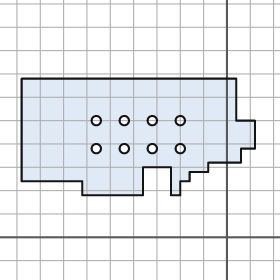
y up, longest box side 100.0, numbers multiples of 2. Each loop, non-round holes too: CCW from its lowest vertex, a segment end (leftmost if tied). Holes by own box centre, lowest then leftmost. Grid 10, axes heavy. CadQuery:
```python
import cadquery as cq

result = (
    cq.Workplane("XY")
    .moveTo(-62.0, 18.0)
    .lineTo(-36.0, 18.0)
    .lineTo(-36.0, 30.0)
    .lineTo(-24.0, 30.0)
    .lineTo(-24.0, 18.0)
    .lineTo(-20.0, 18.0)
    .lineTo(-20.0, 24.0)
    .lineTo(-16.0, 24.0)
    .lineTo(-16.0, 28.0)
    .lineTo(-8.0, 28.0)
    .lineTo(-8.0, 32.0)
    .lineTo(6.0, 32.0)
    .lineTo(6.0, 38.0)
    .lineTo(12.0, 38.0)
    .lineTo(12.0, 50.0)
    .lineTo(4.0, 50.0)
    .lineTo(4.0, 68.0)
    .lineTo(-88.0, 68.0)
    .lineTo(-88.0, 24.0)
    .lineTo(-62.0, 24.0)
    .close()
    .moveTo(-56.0, 38.0)
    .circle(2.0)
    .moveTo(-44.0, 38.0)
    .circle(2.0)
    .moveTo(-32.0, 38.0)
    .circle(2.0)
    .moveTo(-20.0, 38.0)
    .circle(2.0)
    .moveTo(-56.0, 50.0)
    .circle(2.0)
    .moveTo(-44.0, 50.0)
    .circle(2.0)
    .moveTo(-32.0, 50.0)
    .circle(2.0)
    .moveTo(-20.0, 50.0)
    .circle(2.0)
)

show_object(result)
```